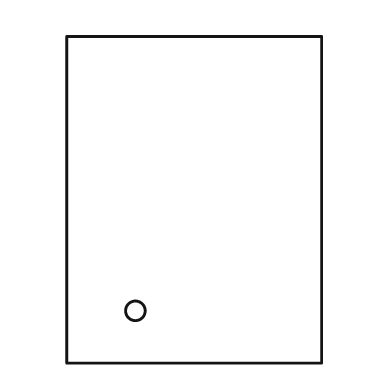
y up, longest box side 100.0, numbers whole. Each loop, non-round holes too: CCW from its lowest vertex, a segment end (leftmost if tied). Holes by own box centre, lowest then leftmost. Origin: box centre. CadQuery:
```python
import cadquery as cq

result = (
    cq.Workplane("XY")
    .moveTo(-39.0, -50.0)
    .lineTo(39.0, -50.0)
    .lineTo(39.0, 50.0)
    .lineTo(-39.0, 50.0)
    .close()
    .moveTo(-18.0, -34.0)
    .circle(3.0)
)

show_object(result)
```